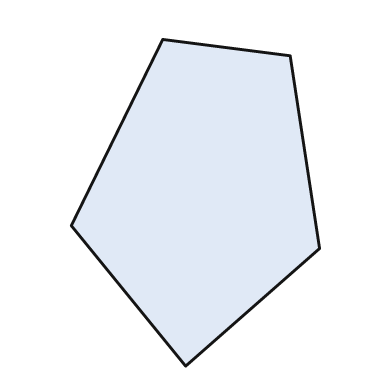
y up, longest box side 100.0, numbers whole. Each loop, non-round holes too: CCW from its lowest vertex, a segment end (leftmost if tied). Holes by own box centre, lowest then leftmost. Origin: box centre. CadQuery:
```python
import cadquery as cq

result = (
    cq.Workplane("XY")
    .moveTo(-3.0, -50.0)
    .lineTo(38.0, -14.0)
    .lineTo(29.0, 45.0)
    .lineTo(-10.0, 50.0)
    .lineTo(-38.0, -7.0)
    .close()
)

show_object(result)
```